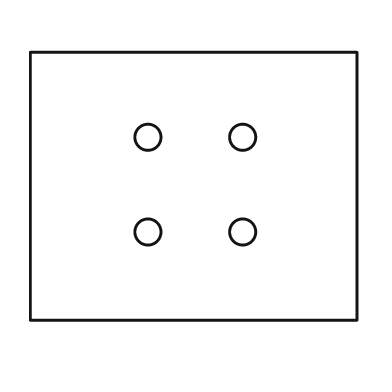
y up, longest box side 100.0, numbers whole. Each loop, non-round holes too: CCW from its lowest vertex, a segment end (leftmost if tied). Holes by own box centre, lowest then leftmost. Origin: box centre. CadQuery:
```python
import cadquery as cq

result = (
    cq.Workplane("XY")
    .moveTo(-50.0, -41.0)
    .lineTo(50.0, -41.0)
    .lineTo(50.0, 41.0)
    .lineTo(-50.0, 41.0)
    .close()
    .moveTo(-14.0, -14.0)
    .circle(4.0)
    .moveTo(15.0, -14.0)
    .circle(4.0)
    .moveTo(-14.0, 15.0)
    .circle(4.0)
    .moveTo(15.0, 15.0)
    .circle(4.0)
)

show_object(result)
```